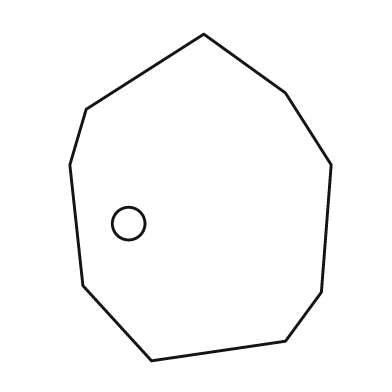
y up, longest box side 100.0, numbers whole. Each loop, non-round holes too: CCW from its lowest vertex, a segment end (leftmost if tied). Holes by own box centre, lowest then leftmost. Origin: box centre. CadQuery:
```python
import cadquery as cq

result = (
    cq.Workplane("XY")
    .moveTo(-15.0, -50.0)
    .lineTo(26.0, -44.0)
    .lineTo(37.0, -29.0)
    .lineTo(40.0, 10.0)
    .lineTo(26.0, 32.0)
    .lineTo(1.0, 50.0)
    .lineTo(-35.0, 27.0)
    .lineTo(-40.0, 10.0)
    .lineTo(-36.0, -27.0)
    .close()
    .moveTo(-22.0, -8.0)
    .circle(5.0)
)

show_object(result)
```